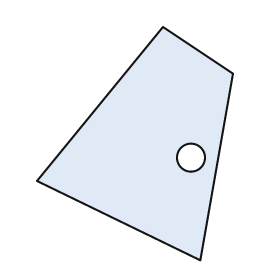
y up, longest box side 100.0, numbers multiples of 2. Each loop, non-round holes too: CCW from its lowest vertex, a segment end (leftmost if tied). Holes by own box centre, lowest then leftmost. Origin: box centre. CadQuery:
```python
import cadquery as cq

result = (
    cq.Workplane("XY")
    .moveTo(28.0, -50.0)
    .lineTo(42.0, 30.0)
    .lineTo(12.0, 50.0)
    .lineTo(-42.0, -16.0)
    .close()
    .moveTo(24.0, -6.0)
    .circle(6.0)
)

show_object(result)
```